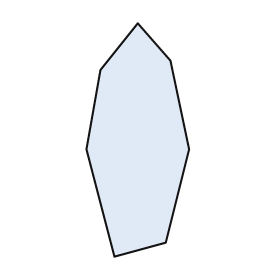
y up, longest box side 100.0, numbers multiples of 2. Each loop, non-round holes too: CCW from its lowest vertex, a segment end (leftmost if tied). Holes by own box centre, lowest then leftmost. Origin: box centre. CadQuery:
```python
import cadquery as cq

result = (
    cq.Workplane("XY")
    .moveTo(-10.0, -50.0)
    .lineTo(12.0, -44.0)
    .lineTo(22.0, -4.0)
    .lineTo(14.0, 34.0)
    .lineTo(0.0, 50.0)
    .lineTo(-16.0, 30.0)
    .lineTo(-22.0, -4.0)
    .close()
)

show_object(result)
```